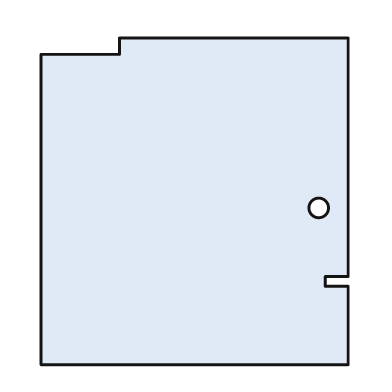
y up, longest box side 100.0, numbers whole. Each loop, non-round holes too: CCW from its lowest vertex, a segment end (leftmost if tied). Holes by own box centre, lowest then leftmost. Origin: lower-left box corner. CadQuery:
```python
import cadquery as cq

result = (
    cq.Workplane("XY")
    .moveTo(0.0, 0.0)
    .lineTo(94.0, 0.0)
    .lineTo(94.0, 24.0)
    .lineTo(87.0, 24.0)
    .lineTo(87.0, 27.0)
    .lineTo(94.0, 27.0)
    .lineTo(94.0, 100.0)
    .lineTo(24.0, 100.0)
    .lineTo(24.0, 95.0)
    .lineTo(0.0, 95.0)
    .close()
    .moveTo(85.0, 48.0)
    .circle(3.0)
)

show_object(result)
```